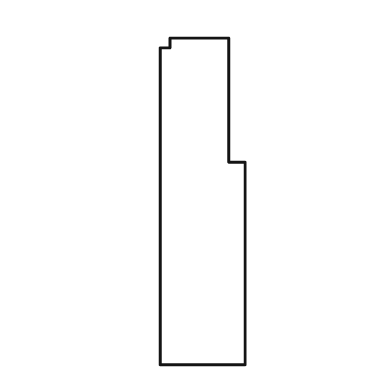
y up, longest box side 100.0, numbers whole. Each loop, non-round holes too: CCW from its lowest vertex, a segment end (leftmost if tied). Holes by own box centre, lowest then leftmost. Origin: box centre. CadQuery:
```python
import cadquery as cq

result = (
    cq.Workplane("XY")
    .moveTo(-13.0, -50.0)
    .lineTo(13.0, -50.0)
    .lineTo(13.0, 12.0)
    .lineTo(8.0, 12.0)
    .lineTo(8.0, 50.0)
    .lineTo(-10.0, 50.0)
    .lineTo(-10.0, 47.0)
    .lineTo(-13.0, 47.0)
    .close()
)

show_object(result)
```